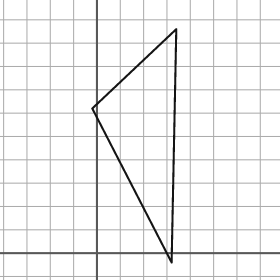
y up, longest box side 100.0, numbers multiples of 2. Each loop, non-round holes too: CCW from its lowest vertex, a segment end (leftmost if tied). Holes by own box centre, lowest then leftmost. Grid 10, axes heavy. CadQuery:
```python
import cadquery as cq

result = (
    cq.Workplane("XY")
    .moveTo(32.0, -4.0)
    .lineTo(34.0, 96.0)
    .lineTo(-2.0, 62.0)
    .close()
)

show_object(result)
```